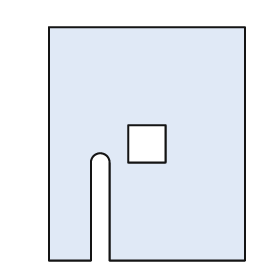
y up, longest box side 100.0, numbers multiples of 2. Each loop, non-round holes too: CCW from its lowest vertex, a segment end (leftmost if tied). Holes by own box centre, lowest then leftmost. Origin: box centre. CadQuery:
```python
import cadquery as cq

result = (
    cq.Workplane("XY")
    .moveTo(-42.0, -50.0)
    .lineTo(-24.0, -50.0)
    .lineTo(-24.0, -8.0)
    .threePointArc((-20.0, -4.0), (-16.0, -8.0))
    .lineTo(-16.0, -50.0)
    .lineTo(42.0, -50.0)
    .lineTo(42.0, 50.0)
    .lineTo(-42.0, 50.0)
    .close()
    .moveTo(-8.0, -8.0)
    .lineTo(8.0, -8.0)
    .lineTo(8.0, 8.0)
    .lineTo(-8.0, 8.0)
    .close()
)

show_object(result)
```